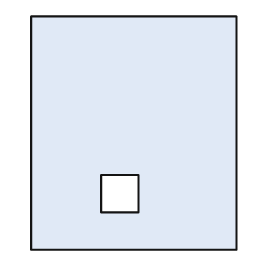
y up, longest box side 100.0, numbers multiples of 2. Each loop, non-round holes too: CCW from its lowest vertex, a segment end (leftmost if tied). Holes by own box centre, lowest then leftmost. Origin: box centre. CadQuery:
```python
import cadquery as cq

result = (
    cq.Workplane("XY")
    .moveTo(-44.0, -50.0)
    .lineTo(44.0, -50.0)
    .lineTo(44.0, 50.0)
    .lineTo(-44.0, 50.0)
    .close()
    .moveTo(-14.0, -34.0)
    .lineTo(2.0, -34.0)
    .lineTo(2.0, -18.0)
    .lineTo(-14.0, -18.0)
    .close()
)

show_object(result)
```